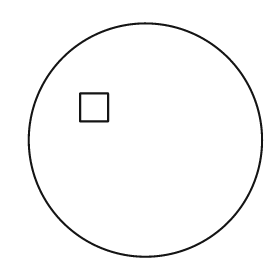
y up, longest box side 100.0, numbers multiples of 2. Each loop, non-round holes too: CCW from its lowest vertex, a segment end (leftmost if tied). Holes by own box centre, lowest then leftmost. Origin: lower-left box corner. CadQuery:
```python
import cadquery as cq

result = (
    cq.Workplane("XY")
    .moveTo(50.0, 50.0)
    .circle(50.0)
    .moveTo(22.0, 58.0)
    .lineTo(34.0, 58.0)
    .lineTo(34.0, 70.0)
    .lineTo(22.0, 70.0)
    .close()
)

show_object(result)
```